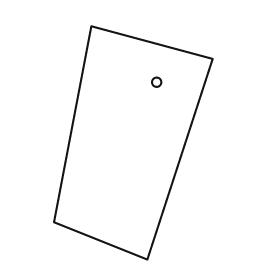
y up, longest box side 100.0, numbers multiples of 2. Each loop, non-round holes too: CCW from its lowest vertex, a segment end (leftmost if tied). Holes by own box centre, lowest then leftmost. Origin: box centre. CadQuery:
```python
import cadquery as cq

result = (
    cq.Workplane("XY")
    .moveTo(6.0, -50.0)
    .lineTo(34.0, 36.0)
    .lineTo(-18.0, 50.0)
    .lineTo(-34.0, -34.0)
    .close()
    .moveTo(10.0, 26.0)
    .circle(2.0)
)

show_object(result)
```